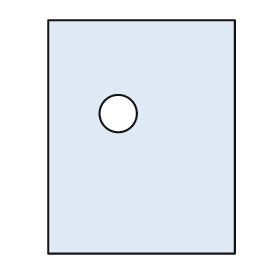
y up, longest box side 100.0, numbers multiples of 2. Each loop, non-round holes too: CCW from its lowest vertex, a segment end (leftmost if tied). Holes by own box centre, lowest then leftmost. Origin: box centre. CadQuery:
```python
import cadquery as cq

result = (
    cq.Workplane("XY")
    .moveTo(-40.0, -50.0)
    .lineTo(40.0, -50.0)
    .lineTo(40.0, 50.0)
    .lineTo(-40.0, 50.0)
    .close()
    .moveTo(-10.0, 10.0)
    .circle(8.0)
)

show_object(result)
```